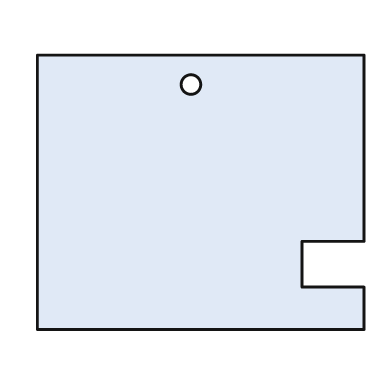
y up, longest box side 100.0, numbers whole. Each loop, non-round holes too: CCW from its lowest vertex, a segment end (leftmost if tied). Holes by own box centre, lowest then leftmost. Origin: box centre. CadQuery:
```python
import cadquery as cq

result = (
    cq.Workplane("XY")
    .moveTo(-50.0, -42.0)
    .lineTo(50.0, -42.0)
    .lineTo(50.0, -29.0)
    .lineTo(31.0, -29.0)
    .lineTo(31.0, -15.0)
    .lineTo(50.0, -15.0)
    .lineTo(50.0, 42.0)
    .lineTo(-50.0, 42.0)
    .close()
    .moveTo(-3.0, 33.0)
    .circle(3.0)
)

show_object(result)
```